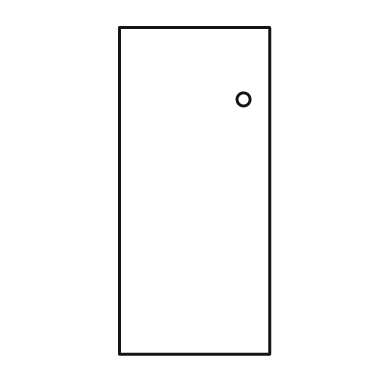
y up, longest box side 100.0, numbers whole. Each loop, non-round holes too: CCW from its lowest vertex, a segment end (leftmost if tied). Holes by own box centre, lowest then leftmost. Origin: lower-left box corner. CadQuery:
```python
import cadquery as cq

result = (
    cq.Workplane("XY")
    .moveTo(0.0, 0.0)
    .lineTo(46.0, 0.0)
    .lineTo(46.0, 100.0)
    .lineTo(0.0, 100.0)
    .close()
    .moveTo(38.0, 78.0)
    .circle(2.0)
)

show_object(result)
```